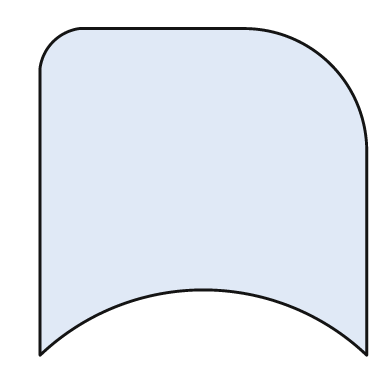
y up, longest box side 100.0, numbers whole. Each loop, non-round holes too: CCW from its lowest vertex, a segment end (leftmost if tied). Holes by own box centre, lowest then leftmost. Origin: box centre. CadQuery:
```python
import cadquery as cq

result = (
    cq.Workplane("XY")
    .moveTo(-50.0, -50.0)
    .threePointArc((0.0, -30.0), (50.0, -50.0))
    .lineTo(50.0, 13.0)
    .threePointArc((39.0, 39.0), (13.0, 50.0))
    .lineTo(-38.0, 50.0)
    .threePointArc((-46.0, 46.0), (-50.0, 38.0))
    .close()
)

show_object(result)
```